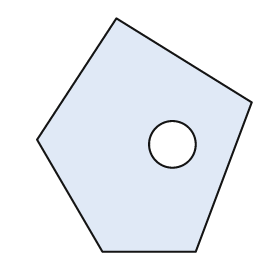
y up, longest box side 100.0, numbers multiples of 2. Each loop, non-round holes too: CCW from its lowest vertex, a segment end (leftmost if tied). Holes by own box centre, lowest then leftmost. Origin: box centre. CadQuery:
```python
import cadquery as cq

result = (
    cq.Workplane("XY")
    .moveTo(-18.0, -50.0)
    .lineTo(22.0, -50.0)
    .lineTo(46.0, 14.0)
    .lineTo(-12.0, 50.0)
    .lineTo(-46.0, -2.0)
    .close()
    .moveTo(12.0, -4.0)
    .circle(10.0)
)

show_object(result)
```